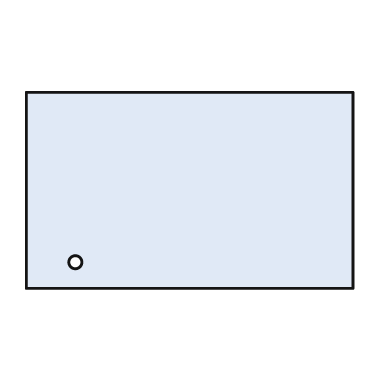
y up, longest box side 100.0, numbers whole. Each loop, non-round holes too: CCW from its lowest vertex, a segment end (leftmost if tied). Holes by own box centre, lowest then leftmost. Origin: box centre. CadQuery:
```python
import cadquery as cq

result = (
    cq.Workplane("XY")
    .moveTo(-50.0, -30.0)
    .lineTo(50.0, -30.0)
    .lineTo(50.0, 30.0)
    .lineTo(-50.0, 30.0)
    .close()
    .moveTo(-35.0, -22.0)
    .circle(2.0)
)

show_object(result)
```